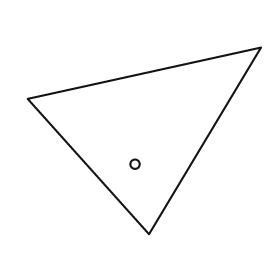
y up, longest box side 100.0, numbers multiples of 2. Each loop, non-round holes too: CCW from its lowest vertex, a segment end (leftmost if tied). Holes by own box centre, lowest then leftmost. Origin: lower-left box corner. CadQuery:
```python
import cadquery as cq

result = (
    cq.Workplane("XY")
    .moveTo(52.0, 0.0)
    .lineTo(100.0, 80.0)
    .lineTo(0.0, 58.0)
    .close()
    .moveTo(46.0, 30.0)
    .circle(2.0)
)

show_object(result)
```